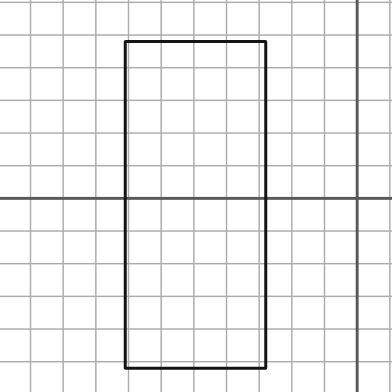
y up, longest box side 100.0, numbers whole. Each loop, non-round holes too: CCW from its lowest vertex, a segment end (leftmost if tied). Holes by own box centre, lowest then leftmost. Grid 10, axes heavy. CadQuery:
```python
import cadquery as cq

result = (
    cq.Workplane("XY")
    .moveTo(-71.0, -52.0)
    .lineTo(-28.0, -52.0)
    .lineTo(-28.0, 48.0)
    .lineTo(-71.0, 48.0)
    .close()
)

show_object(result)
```